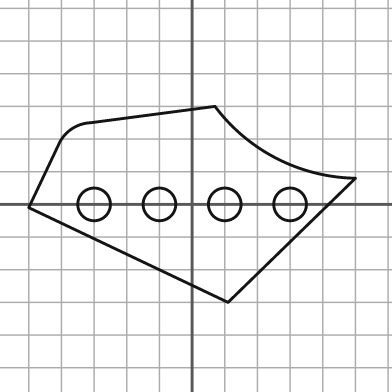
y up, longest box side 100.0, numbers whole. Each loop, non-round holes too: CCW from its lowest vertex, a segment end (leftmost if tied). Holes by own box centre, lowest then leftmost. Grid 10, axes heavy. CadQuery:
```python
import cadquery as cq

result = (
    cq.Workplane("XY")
    .moveTo(11.0, -30.0)
    .lineTo(50.0, 8.0)
    .threePointArc((26.0, 14.0), (7.0, 30.0))
    .lineTo(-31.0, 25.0)
    .threePointArc((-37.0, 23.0), (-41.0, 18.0))
    .lineTo(-50.0, -1.0)
    .close()
    .moveTo(-30.0, 0.0)
    .circle(5.0)
    .moveTo(-10.0, 0.0)
    .circle(5.0)
    .moveTo(10.0, 0.0)
    .circle(5.0)
    .moveTo(30.0, 0.0)
    .circle(5.0)
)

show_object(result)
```